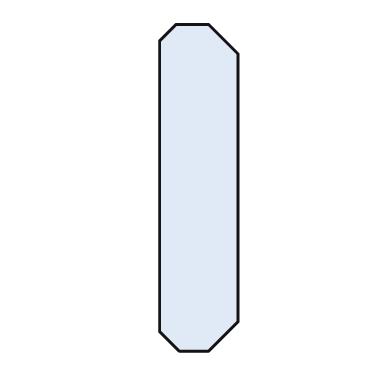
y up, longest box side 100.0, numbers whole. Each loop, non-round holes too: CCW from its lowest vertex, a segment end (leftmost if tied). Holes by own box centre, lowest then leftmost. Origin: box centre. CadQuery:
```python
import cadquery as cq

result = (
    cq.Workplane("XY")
    .moveTo(-6.0, -50.0)
    .lineTo(3.0, -50.0)
    .lineTo(12.0, -41.0)
    .lineTo(12.0, 41.0)
    .lineTo(3.0, 50.0)
    .lineTo(-7.0, 50.0)
    .lineTo(-12.0, 45.0)
    .lineTo(-12.0, -44.0)
    .close()
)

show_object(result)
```